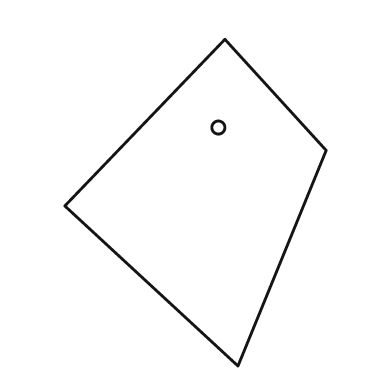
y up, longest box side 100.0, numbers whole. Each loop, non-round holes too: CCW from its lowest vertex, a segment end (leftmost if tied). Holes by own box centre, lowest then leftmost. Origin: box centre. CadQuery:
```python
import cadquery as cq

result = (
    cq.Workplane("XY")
    .moveTo(13.0, -50.0)
    .lineTo(40.0, 16.0)
    .lineTo(9.0, 50.0)
    .lineTo(-40.0, -1.0)
    .close()
    .moveTo(7.0, 23.0)
    .circle(2.0)
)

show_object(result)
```